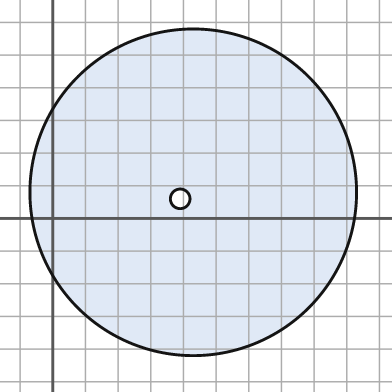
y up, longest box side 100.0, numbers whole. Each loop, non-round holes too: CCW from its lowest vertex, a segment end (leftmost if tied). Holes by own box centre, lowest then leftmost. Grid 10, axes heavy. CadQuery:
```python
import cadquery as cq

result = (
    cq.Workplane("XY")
    .moveTo(43.0, 8.0)
    .circle(50.0)
    .moveTo(39.0, 6.0)
    .circle(3.0)
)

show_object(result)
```